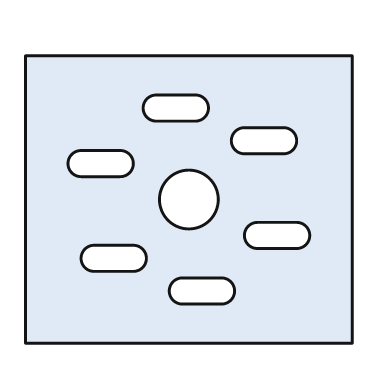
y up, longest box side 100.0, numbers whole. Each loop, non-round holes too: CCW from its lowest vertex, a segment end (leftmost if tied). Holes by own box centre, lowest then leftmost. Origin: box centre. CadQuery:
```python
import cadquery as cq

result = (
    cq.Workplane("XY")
    .moveTo(-50.0, -44.0)
    .lineTo(50.0, -44.0)
    .lineTo(50.0, 44.0)
    .lineTo(-50.0, 44.0)
    .close()
    .moveTo(-2.0, -32.0)
    .lineTo(10.0, -32.0)
    .threePointArc((14.0, -28.0), (10.0, -24.0))
    .lineTo(-2.0, -24.0)
    .threePointArc((-6.0, -28.0), (-2.0, -32.0))
    .close()
    .moveTo(-29.0, -22.0)
    .lineTo(-17.0, -22.0)
    .threePointArc((-13.0, -18.0), (-17.0, -14.0))
    .lineTo(-29.0, -14.0)
    .threePointArc((-33.0, -18.0), (-29.0, -22.0))
    .close()
    .moveTo(21.0, -15.0)
    .lineTo(33.0, -15.0)
    .threePointArc((37.0, -11.0), (33.0, -7.0))
    .lineTo(21.0, -7.0)
    .threePointArc((17.0, -11.0), (21.0, -15.0))
    .close()
    .moveTo(0.0, 0.0)
    .circle(9.0)
    .moveTo(-33.0, 7.0)
    .lineTo(-21.0, 7.0)
    .threePointArc((-17.0, 11.0), (-21.0, 15.0))
    .lineTo(-33.0, 15.0)
    .threePointArc((-37.0, 11.0), (-33.0, 7.0))
    .close()
    .moveTo(17.0, 14.0)
    .lineTo(29.0, 14.0)
    .threePointArc((33.0, 18.0), (29.0, 22.0))
    .lineTo(17.0, 22.0)
    .threePointArc((13.0, 18.0), (17.0, 14.0))
    .close()
    .moveTo(-10.0, 24.0)
    .lineTo(2.0, 24.0)
    .threePointArc((6.0, 28.0), (2.0, 32.0))
    .lineTo(-10.0, 32.0)
    .threePointArc((-14.0, 28.0), (-10.0, 24.0))
    .close()
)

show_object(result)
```